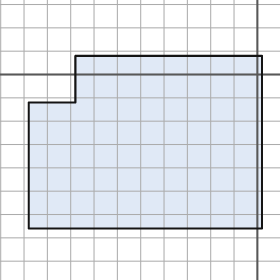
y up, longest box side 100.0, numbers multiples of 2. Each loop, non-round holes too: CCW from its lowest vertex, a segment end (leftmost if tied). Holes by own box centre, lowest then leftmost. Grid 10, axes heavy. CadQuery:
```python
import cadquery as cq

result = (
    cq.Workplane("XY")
    .moveTo(-98.0, -66.0)
    .lineTo(2.0, -66.0)
    .lineTo(2.0, 8.0)
    .lineTo(-78.0, 8.0)
    .lineTo(-78.0, -12.0)
    .lineTo(-98.0, -12.0)
    .close()
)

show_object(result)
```